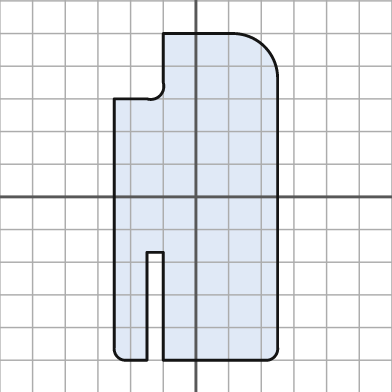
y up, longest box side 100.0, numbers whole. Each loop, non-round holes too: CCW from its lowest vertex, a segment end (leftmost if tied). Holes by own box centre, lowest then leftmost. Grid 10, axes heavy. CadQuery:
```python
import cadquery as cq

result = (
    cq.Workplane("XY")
    .moveTo(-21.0, -50.0)
    .lineTo(-15.0, -50.0)
    .lineTo(-15.0, -17.0)
    .lineTo(-10.0, -17.0)
    .lineTo(-10.0, -50.0)
    .lineTo(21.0, -50.0)
    .threePointArc((24.0, -49.0), (25.0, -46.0))
    .lineTo(25.0, 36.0)
    .threePointArc((21.0, 46.0), (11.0, 50.0))
    .lineTo(-10.0, 50.0)
    .lineTo(-10.0, 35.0)
    .threePointArc((-11.0, 31.0), (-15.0, 30.0))
    .lineTo(-25.0, 30.0)
    .lineTo(-25.0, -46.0)
    .threePointArc((-24.0, -49.0), (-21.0, -50.0))
    .close()
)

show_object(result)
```